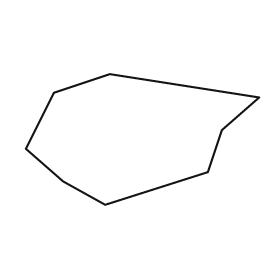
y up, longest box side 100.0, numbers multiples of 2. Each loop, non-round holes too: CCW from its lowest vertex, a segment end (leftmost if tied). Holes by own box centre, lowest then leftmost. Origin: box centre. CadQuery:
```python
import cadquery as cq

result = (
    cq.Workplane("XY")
    .moveTo(-16.0, -28.0)
    .lineTo(28.0, -14.0)
    .lineTo(34.0, 4.0)
    .lineTo(50.0, 18.0)
    .lineTo(-14.0, 28.0)
    .lineTo(-38.0, 20.0)
    .lineTo(-50.0, -4.0)
    .lineTo(-34.0, -18.0)
    .close()
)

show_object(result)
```